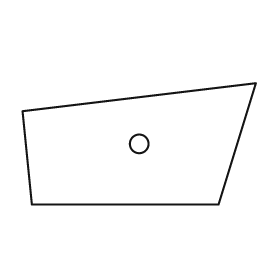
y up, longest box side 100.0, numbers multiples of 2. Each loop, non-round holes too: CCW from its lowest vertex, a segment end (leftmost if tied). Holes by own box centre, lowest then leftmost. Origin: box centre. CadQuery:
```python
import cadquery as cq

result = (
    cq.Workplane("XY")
    .moveTo(-46.0, -26.0)
    .lineTo(34.0, -26.0)
    .lineTo(50.0, 26.0)
    .lineTo(-50.0, 14.0)
    .close()
    .moveTo(0.0, 0.0)
    .circle(4.0)
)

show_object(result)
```